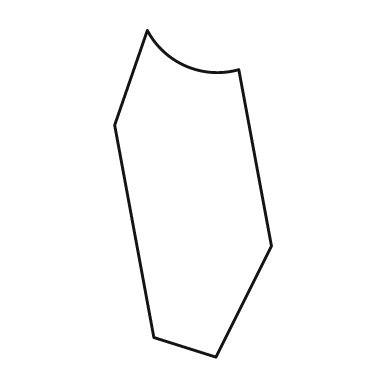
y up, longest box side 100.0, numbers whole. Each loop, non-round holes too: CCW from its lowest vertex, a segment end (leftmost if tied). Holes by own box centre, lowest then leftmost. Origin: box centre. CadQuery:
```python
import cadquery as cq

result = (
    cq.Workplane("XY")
    .moveTo(7.0, -50.0)
    .lineTo(24.0, -16.0)
    .lineTo(14.0, 38.0)
    .threePointArc((-2.0, 39.0), (-14.0, 50.0))
    .lineTo(-24.0, 21.0)
    .lineTo(-12.0, -44.0)
    .close()
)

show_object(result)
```